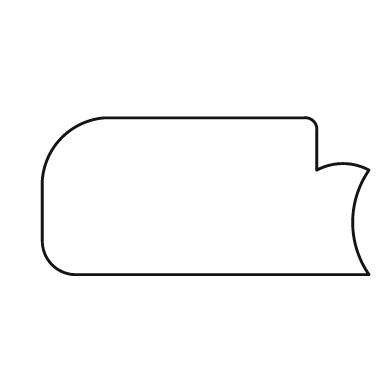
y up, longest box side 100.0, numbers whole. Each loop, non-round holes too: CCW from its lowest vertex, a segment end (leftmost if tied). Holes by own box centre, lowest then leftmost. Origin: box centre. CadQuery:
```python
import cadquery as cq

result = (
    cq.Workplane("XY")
    .moveTo(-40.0, -24.0)
    .lineTo(50.0, -24.0)
    .threePointArc((45.0, -8.0), (50.0, 8.0))
    .threePointArc((42.0, 10.0), (34.0, 8.0))
    .lineTo(34.0, 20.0)
    .threePointArc((33.0, 23.0), (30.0, 24.0))
    .lineTo(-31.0, 24.0)
    .threePointArc((-44.0, 18.0), (-50.0, 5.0))
    .lineTo(-50.0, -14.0)
    .threePointArc((-47.0, -21.0), (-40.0, -24.0))
    .close()
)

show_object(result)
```